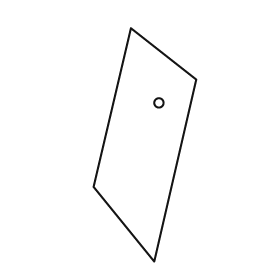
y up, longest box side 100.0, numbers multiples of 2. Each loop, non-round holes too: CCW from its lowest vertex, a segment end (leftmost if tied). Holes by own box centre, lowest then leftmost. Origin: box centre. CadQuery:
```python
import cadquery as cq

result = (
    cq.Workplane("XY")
    .moveTo(4.0, -50.0)
    .lineTo(22.0, 28.0)
    .lineTo(-6.0, 50.0)
    .lineTo(-22.0, -18.0)
    .close()
    .moveTo(6.0, 18.0)
    .circle(2.0)
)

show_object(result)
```